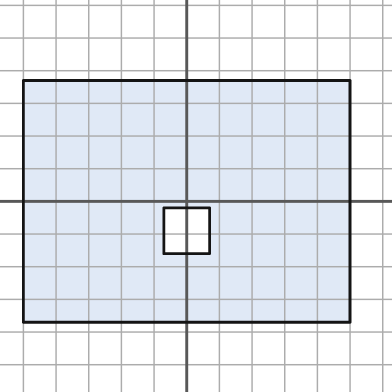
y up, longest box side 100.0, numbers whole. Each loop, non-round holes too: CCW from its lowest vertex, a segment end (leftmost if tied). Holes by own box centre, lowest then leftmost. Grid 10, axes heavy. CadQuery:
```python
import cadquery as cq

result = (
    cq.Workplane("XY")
    .moveTo(-50.0, -37.0)
    .lineTo(50.0, -37.0)
    .lineTo(50.0, 37.0)
    .lineTo(-50.0, 37.0)
    .close()
    .moveTo(-7.0, -16.0)
    .lineTo(7.0, -16.0)
    .lineTo(7.0, -2.0)
    .lineTo(-7.0, -2.0)
    .close()
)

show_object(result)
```